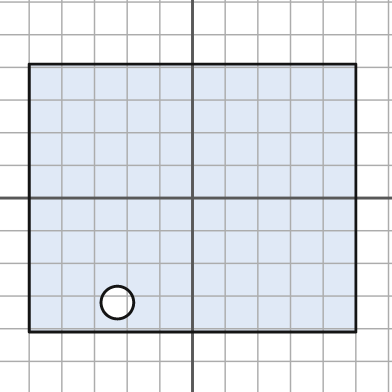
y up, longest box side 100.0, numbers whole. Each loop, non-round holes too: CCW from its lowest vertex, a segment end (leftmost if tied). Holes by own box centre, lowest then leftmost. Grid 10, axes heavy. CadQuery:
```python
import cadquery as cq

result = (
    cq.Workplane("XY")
    .moveTo(-50.0, -41.0)
    .lineTo(50.0, -41.0)
    .lineTo(50.0, 41.0)
    .lineTo(-50.0, 41.0)
    .close()
    .moveTo(-23.0, -32.0)
    .circle(5.0)
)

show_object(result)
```